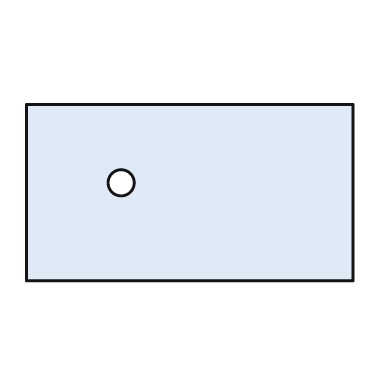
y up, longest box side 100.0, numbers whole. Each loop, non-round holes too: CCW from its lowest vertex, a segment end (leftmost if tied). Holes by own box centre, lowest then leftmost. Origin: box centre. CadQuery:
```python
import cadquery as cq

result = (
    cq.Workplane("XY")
    .moveTo(-50.0, -27.0)
    .lineTo(50.0, -27.0)
    .lineTo(50.0, 27.0)
    .lineTo(-50.0, 27.0)
    .close()
    .moveTo(-21.0, 3.0)
    .circle(4.0)
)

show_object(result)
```